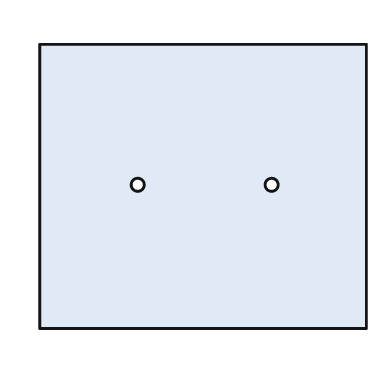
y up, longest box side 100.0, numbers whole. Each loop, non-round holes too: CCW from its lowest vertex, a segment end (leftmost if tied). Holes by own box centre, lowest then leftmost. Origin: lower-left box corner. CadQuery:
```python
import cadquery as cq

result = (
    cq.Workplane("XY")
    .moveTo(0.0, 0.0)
    .lineTo(100.0, 0.0)
    .lineTo(100.0, 87.0)
    .lineTo(0.0, 87.0)
    .close()
    .moveTo(30.0, 44.0)
    .circle(2.0)
    .moveTo(71.0, 44.0)
    .circle(2.0)
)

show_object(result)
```